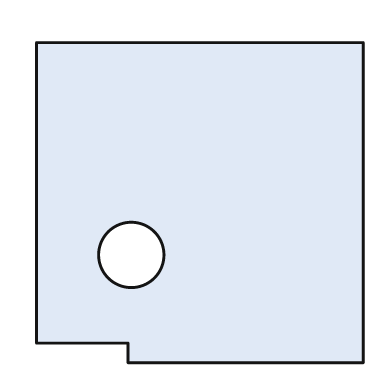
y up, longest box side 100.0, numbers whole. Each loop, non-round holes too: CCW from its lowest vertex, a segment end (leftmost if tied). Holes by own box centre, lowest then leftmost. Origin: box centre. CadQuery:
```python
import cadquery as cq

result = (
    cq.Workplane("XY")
    .moveTo(-22.0, -49.0)
    .lineTo(50.0, -49.0)
    .lineTo(50.0, 49.0)
    .lineTo(-50.0, 49.0)
    .lineTo(-50.0, -43.0)
    .lineTo(-22.0, -43.0)
    .close()
    .moveTo(-21.0, -16.0)
    .circle(10.0)
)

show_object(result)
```